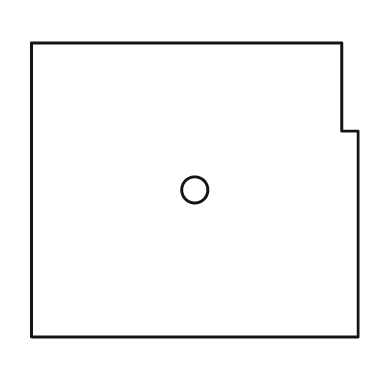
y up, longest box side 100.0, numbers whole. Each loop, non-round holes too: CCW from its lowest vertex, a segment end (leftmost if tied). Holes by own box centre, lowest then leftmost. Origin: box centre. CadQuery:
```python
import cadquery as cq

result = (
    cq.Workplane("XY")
    .moveTo(-50.0, -45.0)
    .lineTo(50.0, -45.0)
    .lineTo(50.0, 18.0)
    .lineTo(45.0, 18.0)
    .lineTo(45.0, 45.0)
    .lineTo(-50.0, 45.0)
    .close()
    .moveTo(0.0, 0.0)
    .circle(4.0)
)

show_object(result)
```